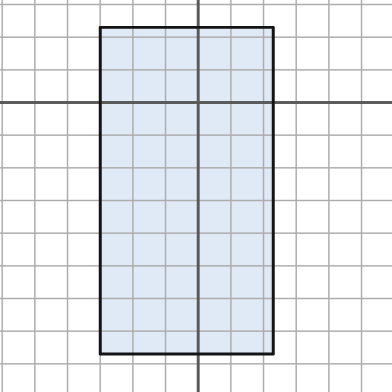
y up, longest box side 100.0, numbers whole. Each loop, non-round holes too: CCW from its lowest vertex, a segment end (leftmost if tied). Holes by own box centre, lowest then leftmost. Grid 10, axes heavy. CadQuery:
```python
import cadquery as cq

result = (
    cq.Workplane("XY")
    .moveTo(-30.0, -77.0)
    .lineTo(23.0, -77.0)
    .lineTo(23.0, 23.0)
    .lineTo(-30.0, 23.0)
    .close()
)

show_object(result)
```